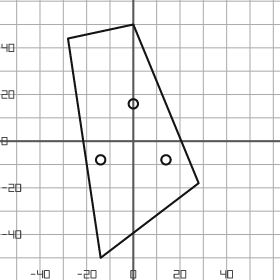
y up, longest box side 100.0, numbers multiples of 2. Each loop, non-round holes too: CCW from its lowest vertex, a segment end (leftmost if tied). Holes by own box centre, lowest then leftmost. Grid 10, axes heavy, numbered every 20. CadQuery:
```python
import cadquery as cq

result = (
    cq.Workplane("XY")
    .moveTo(-14.0, -50.0)
    .lineTo(28.0, -18.0)
    .lineTo(0.0, 50.0)
    .lineTo(-28.0, 44.0)
    .close()
    .moveTo(-14.0, -8.0)
    .circle(2.0)
    .moveTo(14.0, -8.0)
    .circle(2.0)
    .moveTo(0.0, 16.0)
    .circle(2.0)
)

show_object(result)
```